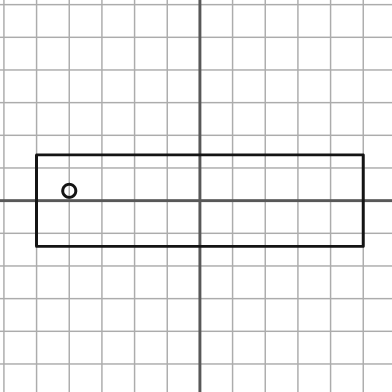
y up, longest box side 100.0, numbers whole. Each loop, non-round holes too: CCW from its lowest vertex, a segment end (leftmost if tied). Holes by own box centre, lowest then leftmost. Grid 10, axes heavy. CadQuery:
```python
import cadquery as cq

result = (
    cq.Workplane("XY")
    .moveTo(-50.0, -14.0)
    .lineTo(50.0, -14.0)
    .lineTo(50.0, 14.0)
    .lineTo(-50.0, 14.0)
    .close()
    .moveTo(-40.0, 3.0)
    .circle(2.0)
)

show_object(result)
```